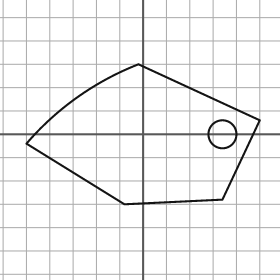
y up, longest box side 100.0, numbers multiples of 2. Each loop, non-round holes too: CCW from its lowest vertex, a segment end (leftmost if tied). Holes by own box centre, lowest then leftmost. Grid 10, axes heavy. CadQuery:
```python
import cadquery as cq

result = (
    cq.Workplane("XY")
    .moveTo(-8.0, -30.0)
    .lineTo(34.0, -28.0)
    .lineTo(50.0, 6.0)
    .lineTo(-2.0, 30.0)
    .threePointArc((-28.0, 16.0), (-50.0, -4.0))
    .close()
    .moveTo(34.0, 0.0)
    .circle(6.0)
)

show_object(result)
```